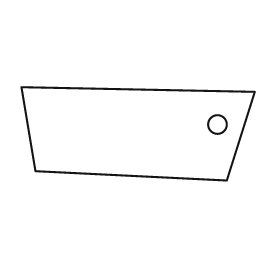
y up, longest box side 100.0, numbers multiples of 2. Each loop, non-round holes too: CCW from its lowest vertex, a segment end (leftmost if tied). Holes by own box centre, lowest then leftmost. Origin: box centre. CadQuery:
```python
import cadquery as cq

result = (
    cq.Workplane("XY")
    .moveTo(38.0, -20.0)
    .lineTo(50.0, 18.0)
    .lineTo(-50.0, 20.0)
    .lineTo(-44.0, -16.0)
    .close()
    .moveTo(34.0, 4.0)
    .circle(4.0)
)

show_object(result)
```